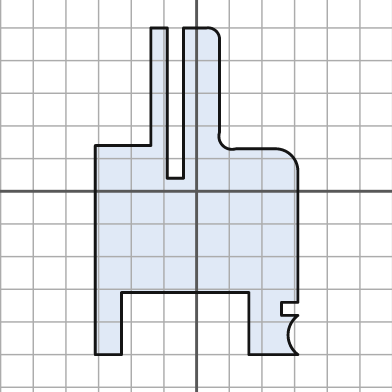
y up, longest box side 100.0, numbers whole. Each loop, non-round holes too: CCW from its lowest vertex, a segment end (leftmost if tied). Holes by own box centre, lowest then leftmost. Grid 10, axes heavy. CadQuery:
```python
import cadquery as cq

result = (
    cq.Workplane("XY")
    .moveTo(-31.0, -50.0)
    .lineTo(-23.0, -50.0)
    .lineTo(-23.0, -31.0)
    .lineTo(16.0, -31.0)
    .lineTo(16.0, -50.0)
    .lineTo(31.0, -50.0)
    .threePointArc((28.0, -44.0), (31.0, -38.0))
    .lineTo(26.0, -38.0)
    .lineTo(26.0, -34.0)
    .lineTo(31.0, -34.0)
    .lineTo(31.0, 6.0)
    .threePointArc((29.0, 11.0), (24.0, 13.0))
    .lineTo(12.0, 13.0)
    .threePointArc((8.0, 14.0), (7.0, 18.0))
    .lineTo(7.0, 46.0)
    .threePointArc((6.0, 49.0), (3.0, 50.0))
    .lineTo(-4.0, 50.0)
    .lineTo(-4.0, 4.0)
    .lineTo(-9.0, 4.0)
    .lineTo(-9.0, 50.0)
    .lineTo(-14.0, 50.0)
    .lineTo(-14.0, 14.0)
    .lineTo(-31.0, 14.0)
    .close()
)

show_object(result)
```